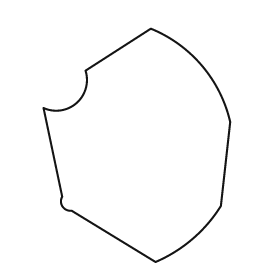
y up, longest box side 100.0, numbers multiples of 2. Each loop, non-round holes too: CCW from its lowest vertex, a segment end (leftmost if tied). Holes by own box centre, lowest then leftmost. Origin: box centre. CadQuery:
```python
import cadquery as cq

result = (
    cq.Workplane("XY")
    .moveTo(8.0, -50.0)
    .threePointArc((24.0, -40.0), (36.0, -26.0))
    .lineTo(40.0, 10.0)
    .threePointArc((28.0, 34.0), (6.0, 50.0))
    .lineTo(-22.0, 32.0)
    .threePointArc((-26.0, 18.0), (-40.0, 16.0))
    .lineTo(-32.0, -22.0)
    .threePointArc((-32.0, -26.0), (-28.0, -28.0))
    .close()
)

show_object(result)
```